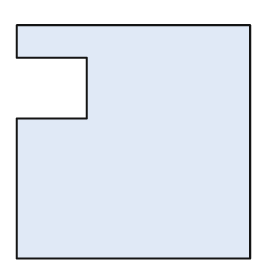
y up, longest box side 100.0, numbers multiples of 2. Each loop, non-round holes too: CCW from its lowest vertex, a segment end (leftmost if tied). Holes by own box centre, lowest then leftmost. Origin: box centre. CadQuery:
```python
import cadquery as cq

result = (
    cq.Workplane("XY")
    .moveTo(-50.0, -50.0)
    .lineTo(50.0, -50.0)
    .lineTo(50.0, 50.0)
    .lineTo(-50.0, 50.0)
    .lineTo(-50.0, 36.0)
    .lineTo(-20.0, 36.0)
    .lineTo(-20.0, 10.0)
    .lineTo(-50.0, 10.0)
    .close()
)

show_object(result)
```